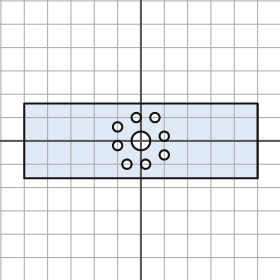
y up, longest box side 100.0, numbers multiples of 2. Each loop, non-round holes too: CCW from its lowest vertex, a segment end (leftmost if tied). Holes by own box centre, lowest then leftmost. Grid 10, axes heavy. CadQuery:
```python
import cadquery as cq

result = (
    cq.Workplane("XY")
    .moveTo(-50.0, -16.0)
    .lineTo(50.0, -16.0)
    .lineTo(50.0, 16.0)
    .lineTo(-50.0, 16.0)
    .close()
    .moveTo(-6.0, -10.0)
    .circle(2.0)
    .moveTo(2.0, -10.0)
    .circle(2.0)
    .moveTo(10.0, -6.0)
    .circle(2.0)
    .moveTo(-10.0, -2.0)
    .circle(2.0)
    .moveTo(0.0, 0.0)
    .circle(4.0)
    .moveTo(10.0, 2.0)
    .circle(2.0)
    .moveTo(-10.0, 6.0)
    .circle(2.0)
    .moveTo(-2.0, 10.0)
    .circle(2.0)
    .moveTo(6.0, 10.0)
    .circle(2.0)
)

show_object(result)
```